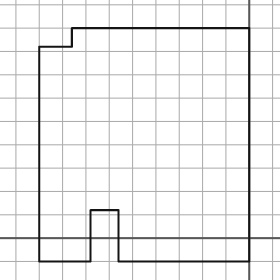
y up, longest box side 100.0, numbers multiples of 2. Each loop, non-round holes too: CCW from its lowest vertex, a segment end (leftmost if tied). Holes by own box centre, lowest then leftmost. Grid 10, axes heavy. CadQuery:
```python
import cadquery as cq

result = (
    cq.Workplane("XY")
    .moveTo(-90.0, -10.0)
    .lineTo(-68.0, -10.0)
    .lineTo(-68.0, 12.0)
    .lineTo(-56.0, 12.0)
    .lineTo(-56.0, -10.0)
    .lineTo(0.0, -10.0)
    .lineTo(0.0, 90.0)
    .lineTo(-76.0, 90.0)
    .lineTo(-76.0, 82.0)
    .lineTo(-90.0, 82.0)
    .close()
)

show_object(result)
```